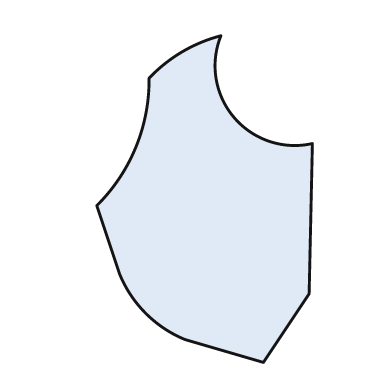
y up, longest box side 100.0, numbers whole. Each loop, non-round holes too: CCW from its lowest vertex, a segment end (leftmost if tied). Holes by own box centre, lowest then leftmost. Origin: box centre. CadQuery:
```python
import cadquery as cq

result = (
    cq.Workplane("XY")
    .moveTo(18.0, -50.0)
    .lineTo(32.0, -29.0)
    .lineTo(33.0, 17.0)
    .threePointArc((9.0, 25.0), (5.0, 50.0))
    .threePointArc((-7.0, 45.0), (-17.0, 37.0))
    .threePointArc((-21.0, 16.0), (-33.0, -2.0))
    .lineTo(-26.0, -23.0)
    .threePointArc((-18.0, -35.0), (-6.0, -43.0))
    .close()
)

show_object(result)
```